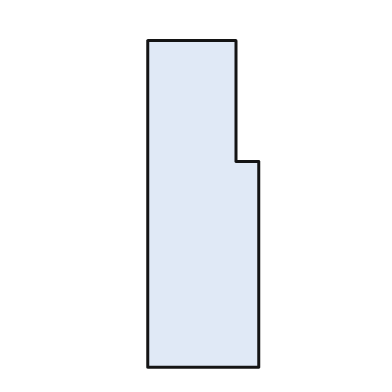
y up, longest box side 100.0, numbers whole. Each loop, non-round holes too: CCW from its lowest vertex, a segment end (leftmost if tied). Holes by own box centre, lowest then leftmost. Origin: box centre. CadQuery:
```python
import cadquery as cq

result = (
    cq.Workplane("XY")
    .moveTo(-17.0, -50.0)
    .lineTo(17.0, -50.0)
    .lineTo(17.0, 13.0)
    .lineTo(10.0, 13.0)
    .lineTo(10.0, 50.0)
    .lineTo(-17.0, 50.0)
    .close()
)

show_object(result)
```